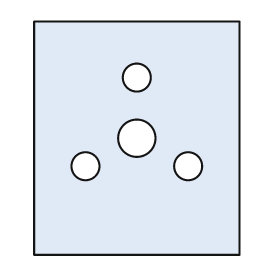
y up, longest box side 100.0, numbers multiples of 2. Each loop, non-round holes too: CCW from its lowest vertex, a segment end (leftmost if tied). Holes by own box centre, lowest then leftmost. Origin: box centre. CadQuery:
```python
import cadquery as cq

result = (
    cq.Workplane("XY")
    .moveTo(-44.0, -50.0)
    .lineTo(44.0, -50.0)
    .lineTo(44.0, 50.0)
    .lineTo(-44.0, 50.0)
    .close()
    .moveTo(-22.0, -12.0)
    .circle(6.0)
    .moveTo(22.0, -12.0)
    .circle(6.0)
    .moveTo(0.0, 0.0)
    .circle(8.0)
    .moveTo(0.0, 26.0)
    .circle(6.0)
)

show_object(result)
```